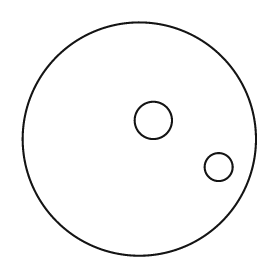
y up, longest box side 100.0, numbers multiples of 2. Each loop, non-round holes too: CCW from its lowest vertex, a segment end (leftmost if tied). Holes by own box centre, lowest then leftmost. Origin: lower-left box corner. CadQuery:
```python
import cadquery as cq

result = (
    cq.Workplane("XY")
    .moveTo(50.0, 50.0)
    .circle(50.0)
    .moveTo(84.0, 38.0)
    .circle(6.0)
    .moveTo(56.0, 58.0)
    .circle(8.0)
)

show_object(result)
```